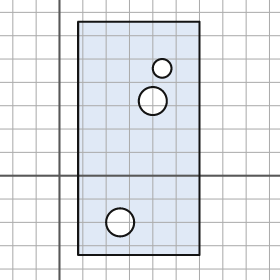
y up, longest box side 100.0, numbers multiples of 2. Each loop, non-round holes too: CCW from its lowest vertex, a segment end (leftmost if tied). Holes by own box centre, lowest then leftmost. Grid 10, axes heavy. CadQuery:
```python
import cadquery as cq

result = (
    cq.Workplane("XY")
    .moveTo(8.0, -34.0)
    .lineTo(60.0, -34.0)
    .lineTo(60.0, 66.0)
    .lineTo(8.0, 66.0)
    .close()
    .moveTo(26.0, -20.0)
    .circle(6.0)
    .moveTo(40.0, 32.0)
    .circle(6.0)
    .moveTo(44.0, 46.0)
    .circle(4.0)
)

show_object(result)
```